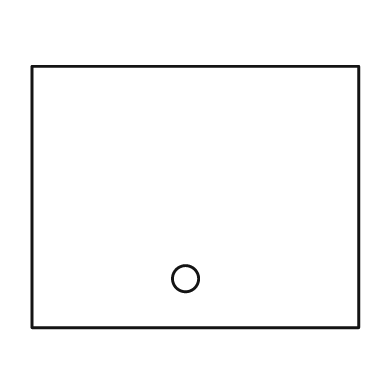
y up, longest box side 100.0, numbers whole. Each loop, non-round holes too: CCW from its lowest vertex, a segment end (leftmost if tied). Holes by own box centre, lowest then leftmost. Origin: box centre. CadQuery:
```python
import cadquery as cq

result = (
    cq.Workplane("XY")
    .moveTo(-50.0, -40.0)
    .lineTo(50.0, -40.0)
    .lineTo(50.0, 40.0)
    .lineTo(-50.0, 40.0)
    .close()
    .moveTo(-3.0, -25.0)
    .circle(4.0)
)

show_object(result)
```